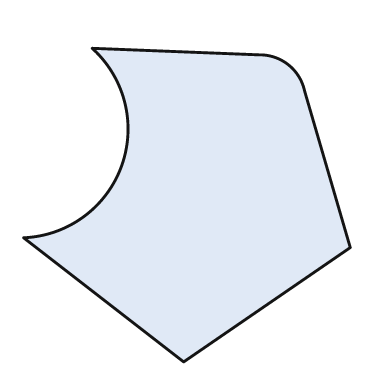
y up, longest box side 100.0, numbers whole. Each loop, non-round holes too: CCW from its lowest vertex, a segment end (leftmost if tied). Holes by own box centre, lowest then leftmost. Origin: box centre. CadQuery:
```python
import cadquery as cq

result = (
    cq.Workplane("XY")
    .moveTo(-1.0, -48.0)
    .lineTo(50.0, -13.0)
    .lineTo(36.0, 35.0)
    .threePointArc((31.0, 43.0), (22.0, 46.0))
    .lineTo(-29.0, 48.0)
    .threePointArc((-20.0, 12.0), (-50.0, -10.0))
    .close()
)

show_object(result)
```